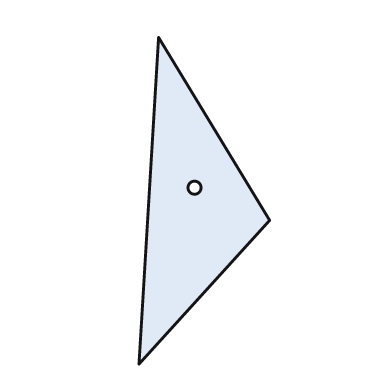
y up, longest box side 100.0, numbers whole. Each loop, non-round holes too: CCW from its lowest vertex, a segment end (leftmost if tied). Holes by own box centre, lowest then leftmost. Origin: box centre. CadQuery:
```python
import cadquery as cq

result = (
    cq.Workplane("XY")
    .moveTo(-20.0, -50.0)
    .lineTo(20.0, -6.0)
    .lineTo(-14.0, 50.0)
    .close()
    .moveTo(-3.0, 4.0)
    .circle(2.0)
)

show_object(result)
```